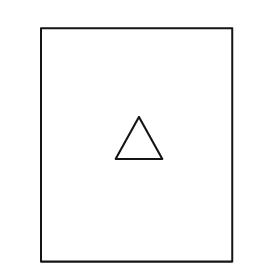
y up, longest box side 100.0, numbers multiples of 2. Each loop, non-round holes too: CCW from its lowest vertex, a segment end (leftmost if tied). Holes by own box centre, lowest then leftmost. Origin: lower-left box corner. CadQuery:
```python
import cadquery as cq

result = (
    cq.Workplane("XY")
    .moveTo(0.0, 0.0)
    .lineTo(82.0, 0.0)
    .lineTo(82.0, 100.0)
    .lineTo(0.0, 100.0)
    .close()
    .moveTo(32.0, 44.0)
    .lineTo(52.0, 44.0)
    .lineTo(42.0, 62.0)
    .close()
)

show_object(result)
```